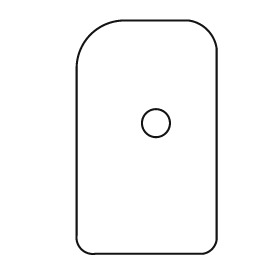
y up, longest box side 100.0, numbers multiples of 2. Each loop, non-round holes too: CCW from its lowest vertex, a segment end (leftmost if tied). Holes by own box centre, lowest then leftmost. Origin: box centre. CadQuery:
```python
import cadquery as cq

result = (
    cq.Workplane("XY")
    .moveTo(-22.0, -50.0)
    .lineTo(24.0, -50.0)
    .threePointArc((28.0, -48.0), (30.0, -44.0))
    .lineTo(30.0, 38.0)
    .threePointArc((26.0, 46.0), (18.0, 50.0))
    .lineTo(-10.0, 50.0)
    .threePointArc((-24.0, 44.0), (-30.0, 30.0))
    .lineTo(-30.0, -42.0)
    .threePointArc((-28.0, -48.0), (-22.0, -50.0))
    .close()
    .moveTo(4.0, 6.0)
    .circle(6.0)
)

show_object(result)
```